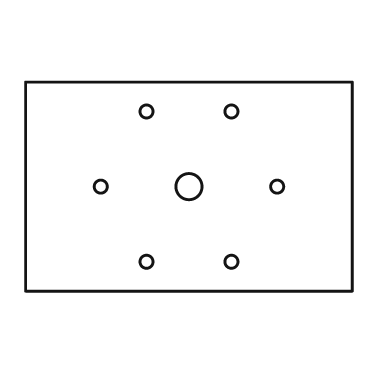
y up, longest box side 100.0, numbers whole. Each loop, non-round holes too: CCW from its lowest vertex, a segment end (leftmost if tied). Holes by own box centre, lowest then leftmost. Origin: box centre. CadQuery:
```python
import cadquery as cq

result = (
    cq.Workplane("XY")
    .moveTo(-50.0, -32.0)
    .lineTo(50.0, -32.0)
    .lineTo(50.0, 32.0)
    .lineTo(-50.0, 32.0)
    .close()
    .moveTo(-13.0, -23.0)
    .circle(2.0)
    .moveTo(13.0, -23.0)
    .circle(2.0)
    .moveTo(-27.0, 0.0)
    .circle(2.0)
    .moveTo(0.0, 0.0)
    .circle(4.0)
    .moveTo(27.0, 0.0)
    .circle(2.0)
    .moveTo(-13.0, 23.0)
    .circle(2.0)
    .moveTo(13.0, 23.0)
    .circle(2.0)
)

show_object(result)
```